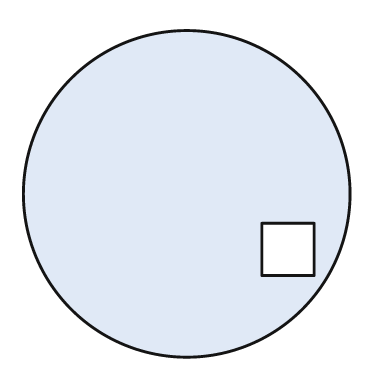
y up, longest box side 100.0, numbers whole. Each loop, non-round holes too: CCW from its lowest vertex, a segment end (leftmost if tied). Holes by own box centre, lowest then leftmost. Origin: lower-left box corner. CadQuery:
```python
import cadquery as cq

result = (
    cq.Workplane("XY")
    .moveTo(50.0, 50.0)
    .circle(50.0)
    .moveTo(73.0, 25.0)
    .lineTo(89.0, 25.0)
    .lineTo(89.0, 41.0)
    .lineTo(73.0, 41.0)
    .close()
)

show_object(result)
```